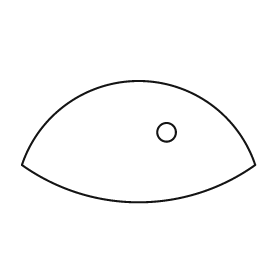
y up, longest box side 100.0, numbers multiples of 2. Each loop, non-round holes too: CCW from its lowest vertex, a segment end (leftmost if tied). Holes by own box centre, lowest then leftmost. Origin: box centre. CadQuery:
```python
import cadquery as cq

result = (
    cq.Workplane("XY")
    .moveTo(-50.0, -10.0)
    .threePointArc((0.0, -26.0), (50.0, -10.0))
    .threePointArc((0.0, 26.0), (-50.0, -10.0))
    .close()
    .moveTo(12.0, 4.0)
    .circle(4.0)
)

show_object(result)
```